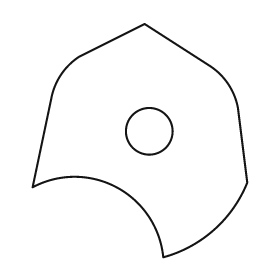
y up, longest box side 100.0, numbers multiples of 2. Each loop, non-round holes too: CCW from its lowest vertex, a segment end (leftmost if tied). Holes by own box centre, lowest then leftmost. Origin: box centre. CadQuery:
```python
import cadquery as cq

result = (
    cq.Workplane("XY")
    .moveTo(10.0, -50.0)
    .threePointArc((32.0, -38.0), (46.0, -18.0))
    .lineTo(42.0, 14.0)
    .threePointArc((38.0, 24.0), (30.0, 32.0))
    .lineTo(2.0, 50.0)
    .lineTo(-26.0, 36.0)
    .threePointArc((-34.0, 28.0), (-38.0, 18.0))
    .lineTo(-46.0, -20.0)
    .threePointArc((-10.0, -20.0), (10.0, -50.0))
    .close()
    .moveTo(4.0, 4.0)
    .circle(10.0)
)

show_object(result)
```